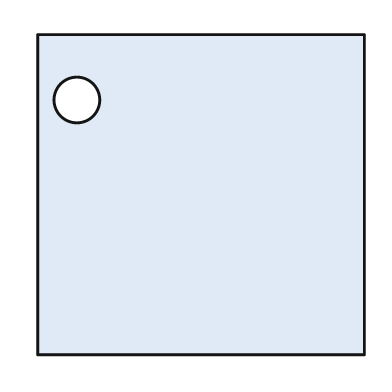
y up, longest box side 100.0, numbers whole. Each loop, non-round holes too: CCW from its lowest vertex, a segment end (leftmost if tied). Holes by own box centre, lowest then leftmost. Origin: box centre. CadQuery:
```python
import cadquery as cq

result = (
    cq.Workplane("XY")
    .moveTo(-50.0, -49.0)
    .lineTo(50.0, -49.0)
    .lineTo(50.0, 49.0)
    .lineTo(-50.0, 49.0)
    .close()
    .moveTo(-38.0, 29.0)
    .circle(7.0)
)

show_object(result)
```